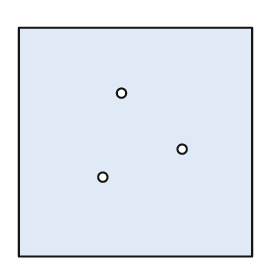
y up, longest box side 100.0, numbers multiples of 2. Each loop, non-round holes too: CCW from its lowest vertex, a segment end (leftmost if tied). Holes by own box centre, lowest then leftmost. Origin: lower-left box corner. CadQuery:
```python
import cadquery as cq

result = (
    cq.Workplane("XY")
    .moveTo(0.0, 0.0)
    .lineTo(100.0, 0.0)
    .lineTo(100.0, 98.0)
    .lineTo(0.0, 98.0)
    .close()
    .moveTo(36.0, 34.0)
    .circle(2.0)
    .moveTo(70.0, 46.0)
    .circle(2.0)
    .moveTo(44.0, 70.0)
    .circle(2.0)
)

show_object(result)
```